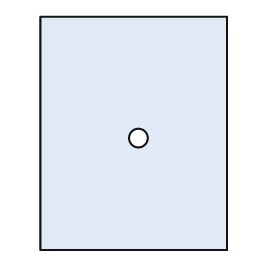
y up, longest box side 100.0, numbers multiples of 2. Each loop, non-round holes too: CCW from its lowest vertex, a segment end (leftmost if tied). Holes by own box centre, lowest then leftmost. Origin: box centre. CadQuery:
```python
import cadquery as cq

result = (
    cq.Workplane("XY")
    .moveTo(-40.0, -50.0)
    .lineTo(40.0, -50.0)
    .lineTo(40.0, 50.0)
    .lineTo(-40.0, 50.0)
    .close()
    .moveTo(2.0, -2.0)
    .circle(4.0)
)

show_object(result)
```